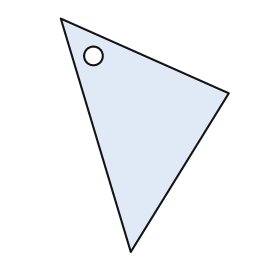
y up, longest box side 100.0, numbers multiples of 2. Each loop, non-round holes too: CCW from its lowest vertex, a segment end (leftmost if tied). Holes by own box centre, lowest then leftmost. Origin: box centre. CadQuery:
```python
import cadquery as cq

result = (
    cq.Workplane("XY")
    .moveTo(-6.0, -50.0)
    .lineTo(36.0, 18.0)
    .lineTo(-36.0, 50.0)
    .close()
    .moveTo(-22.0, 34.0)
    .circle(4.0)
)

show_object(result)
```